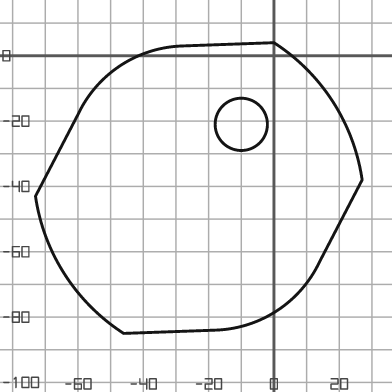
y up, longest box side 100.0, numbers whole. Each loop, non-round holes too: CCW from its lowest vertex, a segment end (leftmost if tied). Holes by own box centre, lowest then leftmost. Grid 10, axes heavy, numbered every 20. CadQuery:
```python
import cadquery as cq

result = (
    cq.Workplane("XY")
    .moveTo(-46.0, -85.0)
    .lineTo(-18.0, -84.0)
    .threePointArc((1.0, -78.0), (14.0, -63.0))
    .lineTo(27.0, -38.0)
    .threePointArc((18.0, -14.0), (0.0, 4.0))
    .lineTo(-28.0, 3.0)
    .threePointArc((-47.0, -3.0), (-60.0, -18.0))
    .lineTo(-73.0, -43.0)
    .threePointArc((-64.0, -67.0), (-46.0, -85.0))
    .close()
    .moveTo(-10.0, -21.0)
    .circle(8.0)
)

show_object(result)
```